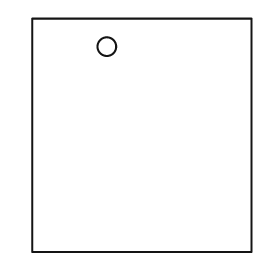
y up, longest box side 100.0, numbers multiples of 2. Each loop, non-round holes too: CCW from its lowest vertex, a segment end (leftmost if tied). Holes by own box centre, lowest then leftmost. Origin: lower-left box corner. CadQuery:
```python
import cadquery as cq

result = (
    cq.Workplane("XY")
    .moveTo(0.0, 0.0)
    .lineTo(94.0, 0.0)
    .lineTo(94.0, 100.0)
    .lineTo(0.0, 100.0)
    .close()
    .moveTo(32.0, 88.0)
    .circle(4.0)
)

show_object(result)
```